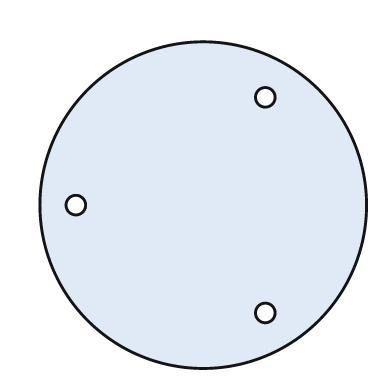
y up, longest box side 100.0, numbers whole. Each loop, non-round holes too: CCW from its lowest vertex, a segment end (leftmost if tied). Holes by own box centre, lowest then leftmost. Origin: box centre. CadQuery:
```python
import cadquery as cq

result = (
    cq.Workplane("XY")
    .moveTo(0.0, 0.0)
    .circle(50.0)
    .moveTo(19.0, -33.0)
    .circle(3.0)
    .moveTo(-39.0, 0.0)
    .circle(3.0)
    .moveTo(19.0, 33.0)
    .circle(3.0)
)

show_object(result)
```